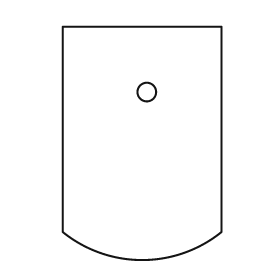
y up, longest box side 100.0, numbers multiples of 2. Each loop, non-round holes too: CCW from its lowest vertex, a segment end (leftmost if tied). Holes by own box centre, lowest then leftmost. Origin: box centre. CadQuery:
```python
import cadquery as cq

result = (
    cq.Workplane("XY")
    .moveTo(-34.0, -38.0)
    .threePointArc((0.0, -50.0), (34.0, -38.0))
    .lineTo(34.0, 50.0)
    .lineTo(-34.0, 50.0)
    .close()
    .moveTo(2.0, 22.0)
    .circle(4.0)
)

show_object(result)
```